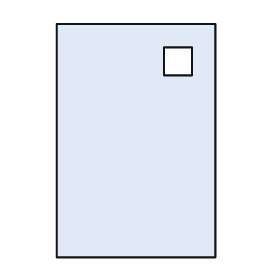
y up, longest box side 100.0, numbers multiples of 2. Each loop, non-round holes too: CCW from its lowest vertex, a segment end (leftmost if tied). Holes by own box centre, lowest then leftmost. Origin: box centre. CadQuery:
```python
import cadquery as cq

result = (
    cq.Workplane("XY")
    .moveTo(-34.0, -50.0)
    .lineTo(34.0, -50.0)
    .lineTo(34.0, 50.0)
    .lineTo(-34.0, 50.0)
    .close()
    .moveTo(12.0, 28.0)
    .lineTo(24.0, 28.0)
    .lineTo(24.0, 40.0)
    .lineTo(12.0, 40.0)
    .close()
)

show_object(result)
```